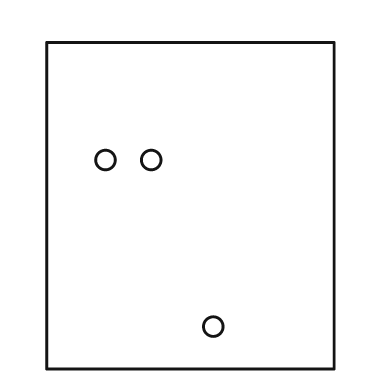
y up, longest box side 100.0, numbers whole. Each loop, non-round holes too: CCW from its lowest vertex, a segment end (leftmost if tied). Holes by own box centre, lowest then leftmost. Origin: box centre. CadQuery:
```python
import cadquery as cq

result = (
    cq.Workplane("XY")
    .moveTo(-44.0, -50.0)
    .lineTo(44.0, -50.0)
    .lineTo(44.0, 50.0)
    .lineTo(-44.0, 50.0)
    .close()
    .moveTo(7.0, -37.0)
    .circle(3.0)
    .moveTo(-26.0, 14.0)
    .circle(3.0)
    .moveTo(-12.0, 14.0)
    .circle(3.0)
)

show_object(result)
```